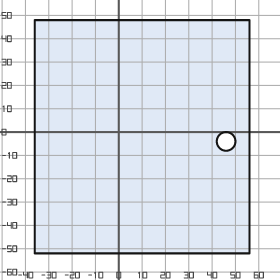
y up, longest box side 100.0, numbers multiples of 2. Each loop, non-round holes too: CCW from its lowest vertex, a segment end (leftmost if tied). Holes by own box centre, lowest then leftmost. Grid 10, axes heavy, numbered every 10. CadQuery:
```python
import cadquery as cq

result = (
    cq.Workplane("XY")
    .moveTo(-36.0, -52.0)
    .lineTo(56.0, -52.0)
    .lineTo(56.0, 48.0)
    .lineTo(-36.0, 48.0)
    .close()
    .moveTo(46.0, -4.0)
    .circle(4.0)
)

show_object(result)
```